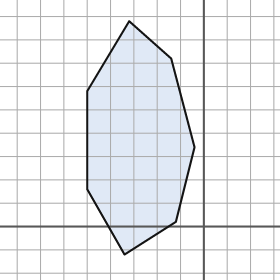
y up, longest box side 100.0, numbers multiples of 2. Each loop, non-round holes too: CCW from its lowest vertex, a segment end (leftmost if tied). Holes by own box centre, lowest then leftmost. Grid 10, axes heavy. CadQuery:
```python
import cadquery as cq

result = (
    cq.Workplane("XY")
    .moveTo(-34.0, -12.0)
    .lineTo(-12.0, 2.0)
    .lineTo(-4.0, 34.0)
    .lineTo(-14.0, 72.0)
    .lineTo(-32.0, 88.0)
    .lineTo(-50.0, 58.0)
    .lineTo(-50.0, 16.0)
    .close()
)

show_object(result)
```